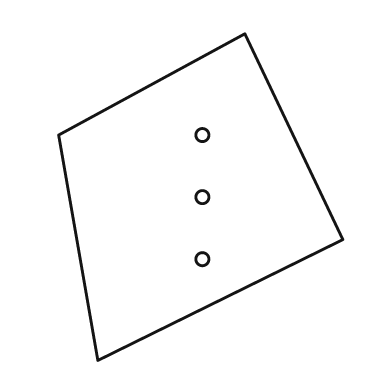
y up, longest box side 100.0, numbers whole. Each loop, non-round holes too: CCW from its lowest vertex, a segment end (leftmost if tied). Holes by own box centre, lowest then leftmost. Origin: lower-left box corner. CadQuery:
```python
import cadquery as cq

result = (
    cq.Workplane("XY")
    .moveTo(12.0, 0.0)
    .lineTo(87.0, 37.0)
    .lineTo(57.0, 100.0)
    .lineTo(0.0, 69.0)
    .close()
    .moveTo(44.0, 31.0)
    .circle(2.0)
    .moveTo(44.0, 50.0)
    .circle(2.0)
    .moveTo(44.0, 69.0)
    .circle(2.0)
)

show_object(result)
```